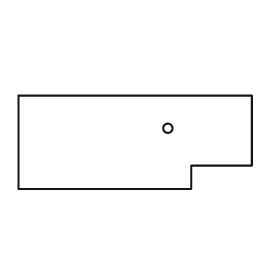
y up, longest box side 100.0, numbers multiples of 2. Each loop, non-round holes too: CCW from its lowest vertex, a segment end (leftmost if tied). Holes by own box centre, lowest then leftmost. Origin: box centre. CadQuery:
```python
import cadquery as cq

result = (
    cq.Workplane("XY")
    .moveTo(-50.0, -20.0)
    .lineTo(24.0, -20.0)
    .lineTo(24.0, -10.0)
    .lineTo(50.0, -10.0)
    .lineTo(50.0, 20.0)
    .lineTo(-50.0, 20.0)
    .close()
    .moveTo(14.0, 6.0)
    .circle(2.0)
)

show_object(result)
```